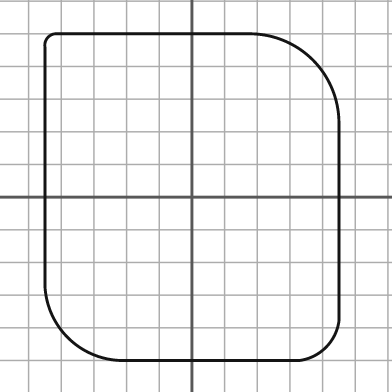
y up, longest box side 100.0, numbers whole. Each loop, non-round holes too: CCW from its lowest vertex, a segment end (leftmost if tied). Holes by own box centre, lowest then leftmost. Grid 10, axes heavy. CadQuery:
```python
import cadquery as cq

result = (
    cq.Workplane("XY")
    .moveTo(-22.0, -50.0)
    .lineTo(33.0, -50.0)
    .threePointArc((41.0, -46.0), (45.0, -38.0))
    .lineTo(45.0, 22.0)
    .threePointArc((37.0, 42.0), (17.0, 50.0))
    .lineTo(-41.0, 50.0)
    .threePointArc((-44.0, 49.0), (-45.0, 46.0))
    .lineTo(-45.0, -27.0)
    .threePointArc((-38.0, -43.0), (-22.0, -50.0))
    .close()
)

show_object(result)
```